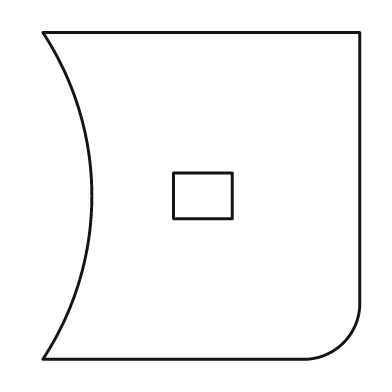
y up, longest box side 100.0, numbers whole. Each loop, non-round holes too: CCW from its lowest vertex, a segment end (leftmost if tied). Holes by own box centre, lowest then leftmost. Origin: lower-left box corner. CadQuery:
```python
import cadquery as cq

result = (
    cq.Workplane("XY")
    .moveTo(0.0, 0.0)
    .lineTo(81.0, 0.0)
    .threePointArc((92.0, 5.0), (97.0, 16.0))
    .lineTo(97.0, 100.0)
    .lineTo(0.0, 100.0)
    .threePointArc((15.0, 50.0), (0.0, 0.0))
    .close()
    .moveTo(40.0, 43.0)
    .lineTo(58.0, 43.0)
    .lineTo(58.0, 57.0)
    .lineTo(40.0, 57.0)
    .close()
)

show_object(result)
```